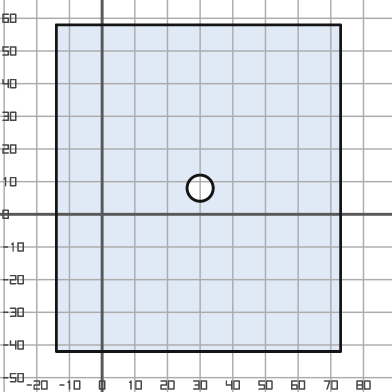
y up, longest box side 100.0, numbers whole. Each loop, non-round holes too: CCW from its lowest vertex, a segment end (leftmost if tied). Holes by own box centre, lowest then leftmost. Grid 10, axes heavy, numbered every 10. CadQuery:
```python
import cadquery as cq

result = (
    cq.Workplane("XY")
    .moveTo(-14.0, -42.0)
    .lineTo(73.0, -42.0)
    .lineTo(73.0, 58.0)
    .lineTo(-14.0, 58.0)
    .close()
    .moveTo(30.0, 8.0)
    .circle(4.0)
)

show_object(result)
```